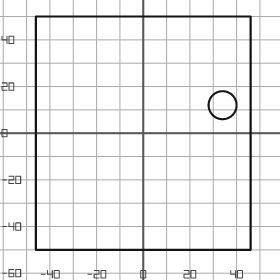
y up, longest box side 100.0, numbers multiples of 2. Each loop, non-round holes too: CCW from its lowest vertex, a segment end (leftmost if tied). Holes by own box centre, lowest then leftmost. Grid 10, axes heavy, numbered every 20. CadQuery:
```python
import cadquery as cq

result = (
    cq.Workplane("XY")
    .moveTo(-46.0, -50.0)
    .lineTo(46.0, -50.0)
    .lineTo(46.0, 50.0)
    .lineTo(-46.0, 50.0)
    .close()
    .moveTo(34.0, 12.0)
    .circle(6.0)
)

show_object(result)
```